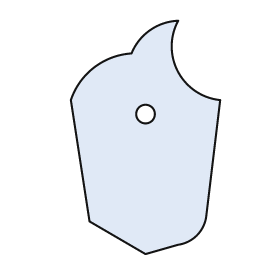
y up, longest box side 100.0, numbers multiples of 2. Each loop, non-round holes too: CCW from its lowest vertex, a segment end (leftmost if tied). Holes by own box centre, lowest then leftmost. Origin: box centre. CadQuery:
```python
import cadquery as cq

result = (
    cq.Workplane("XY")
    .moveTo(0.0, -50.0)
    .lineTo(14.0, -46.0)
    .threePointArc((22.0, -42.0), (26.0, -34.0))
    .lineTo(32.0, 16.0)
    .threePointArc((14.0, 28.0), (14.0, 50.0))
    .threePointArc((2.0, 46.0), (-6.0, 36.0))
    .threePointArc((-22.0, 30.0), (-32.0, 16.0))
    .lineTo(-24.0, -36.0)
    .close()
    .moveTo(0.0, 10.0)
    .circle(4.0)
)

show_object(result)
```